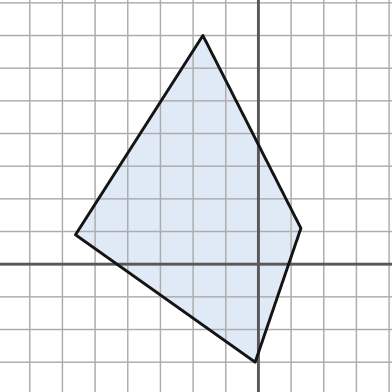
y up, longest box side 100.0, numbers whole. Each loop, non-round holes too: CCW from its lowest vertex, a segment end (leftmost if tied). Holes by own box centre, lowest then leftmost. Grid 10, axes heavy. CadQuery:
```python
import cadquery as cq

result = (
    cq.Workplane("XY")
    .moveTo(-1.0, -30.0)
    .lineTo(13.0, 11.0)
    .lineTo(-17.0, 70.0)
    .lineTo(-56.0, 9.0)
    .close()
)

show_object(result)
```